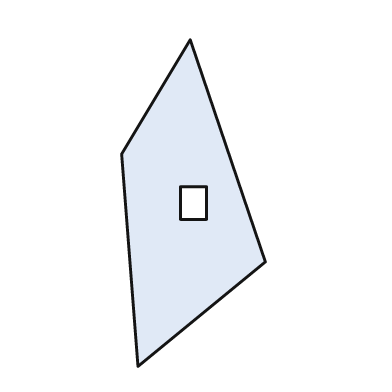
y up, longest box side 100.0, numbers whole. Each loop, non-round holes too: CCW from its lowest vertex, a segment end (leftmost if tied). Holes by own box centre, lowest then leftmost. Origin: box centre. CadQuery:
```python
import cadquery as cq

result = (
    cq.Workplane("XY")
    .moveTo(-17.0, -50.0)
    .lineTo(22.0, -18.0)
    .lineTo(-1.0, 50.0)
    .lineTo(-22.0, 15.0)
    .close()
    .moveTo(-4.0, -5.0)
    .lineTo(4.0, -5.0)
    .lineTo(4.0, 5.0)
    .lineTo(-4.0, 5.0)
    .close()
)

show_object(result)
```